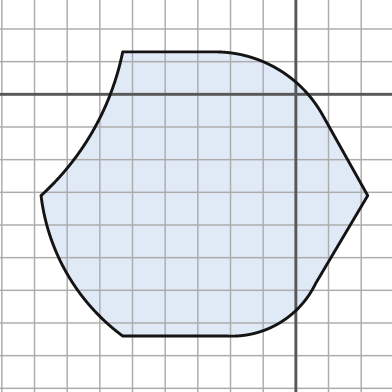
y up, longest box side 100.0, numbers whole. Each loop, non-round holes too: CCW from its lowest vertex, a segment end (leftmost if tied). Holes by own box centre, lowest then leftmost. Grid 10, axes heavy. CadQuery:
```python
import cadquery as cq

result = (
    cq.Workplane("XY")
    .moveTo(-53.0, -74.0)
    .lineTo(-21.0, -74.0)
    .threePointArc((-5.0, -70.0), (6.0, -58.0))
    .lineTo(22.0, -31.0)
    .lineTo(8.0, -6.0)
    .threePointArc((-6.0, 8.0), (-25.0, 13.0))
    .lineTo(-53.0, 13.0)
    .threePointArc((-62.0, -11.0), (-78.0, -31.0))
    .threePointArc((-70.0, -55.0), (-53.0, -74.0))
    .close()
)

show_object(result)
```